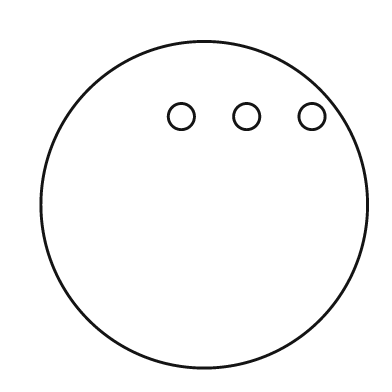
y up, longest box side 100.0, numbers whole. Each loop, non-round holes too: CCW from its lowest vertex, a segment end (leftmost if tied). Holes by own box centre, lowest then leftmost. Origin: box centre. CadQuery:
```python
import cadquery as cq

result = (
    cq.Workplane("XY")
    .moveTo(0.0, 0.0)
    .circle(50.0)
    .moveTo(-7.0, 27.0)
    .circle(4.0)
    .moveTo(13.0, 27.0)
    .circle(4.0)
    .moveTo(33.0, 27.0)
    .circle(4.0)
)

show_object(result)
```